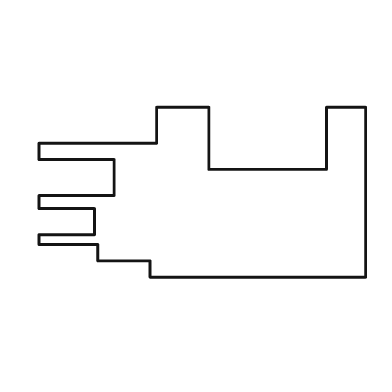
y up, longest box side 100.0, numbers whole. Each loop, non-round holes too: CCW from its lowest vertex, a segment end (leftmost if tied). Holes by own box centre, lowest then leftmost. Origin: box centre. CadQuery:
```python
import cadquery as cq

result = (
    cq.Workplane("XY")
    .moveTo(-16.0, -26.0)
    .lineTo(50.0, -26.0)
    .lineTo(50.0, 26.0)
    .lineTo(38.0, 26.0)
    .lineTo(38.0, 7.0)
    .lineTo(2.0, 7.0)
    .lineTo(2.0, 26.0)
    .lineTo(-14.0, 26.0)
    .lineTo(-14.0, 15.0)
    .lineTo(-50.0, 15.0)
    .lineTo(-50.0, 10.0)
    .lineTo(-27.0, 10.0)
    .lineTo(-27.0, -1.0)
    .lineTo(-50.0, -1.0)
    .lineTo(-50.0, -5.0)
    .lineTo(-33.0, -5.0)
    .lineTo(-33.0, -13.0)
    .lineTo(-50.0, -13.0)
    .lineTo(-50.0, -16.0)
    .lineTo(-32.0, -16.0)
    .lineTo(-32.0, -21.0)
    .lineTo(-16.0, -21.0)
    .close()
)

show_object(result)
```